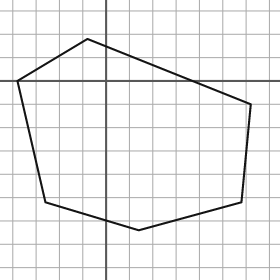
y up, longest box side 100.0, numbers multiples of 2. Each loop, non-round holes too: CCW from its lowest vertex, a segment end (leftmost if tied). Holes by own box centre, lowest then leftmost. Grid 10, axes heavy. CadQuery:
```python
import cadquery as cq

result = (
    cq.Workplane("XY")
    .moveTo(14.0, -64.0)
    .lineTo(58.0, -52.0)
    .lineTo(62.0, -10.0)
    .lineTo(-8.0, 18.0)
    .lineTo(-38.0, 0.0)
    .lineTo(-26.0, -52.0)
    .close()
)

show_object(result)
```